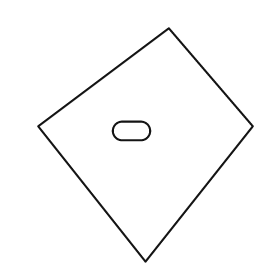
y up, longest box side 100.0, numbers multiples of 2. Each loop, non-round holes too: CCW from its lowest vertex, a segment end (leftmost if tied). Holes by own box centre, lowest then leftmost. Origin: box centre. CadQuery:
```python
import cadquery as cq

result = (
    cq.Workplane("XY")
    .moveTo(0.0, -50.0)
    .lineTo(46.0, 8.0)
    .lineTo(10.0, 50.0)
    .lineTo(-46.0, 8.0)
    .close()
    .moveTo(-10.0, 2.0)
    .lineTo(-2.0, 2.0)
    .threePointArc((2.0, 6.0), (-2.0, 10.0))
    .lineTo(-10.0, 10.0)
    .threePointArc((-14.0, 6.0), (-10.0, 2.0))
    .close()
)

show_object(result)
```